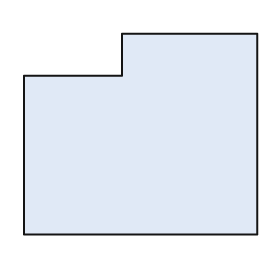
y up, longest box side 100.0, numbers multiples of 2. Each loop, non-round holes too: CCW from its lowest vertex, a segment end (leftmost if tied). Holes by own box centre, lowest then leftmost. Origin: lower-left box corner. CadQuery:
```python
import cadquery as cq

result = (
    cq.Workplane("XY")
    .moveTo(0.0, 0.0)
    .lineTo(100.0, 0.0)
    .lineTo(100.0, 86.0)
    .lineTo(42.0, 86.0)
    .lineTo(42.0, 68.0)
    .lineTo(0.0, 68.0)
    .close()
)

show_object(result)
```